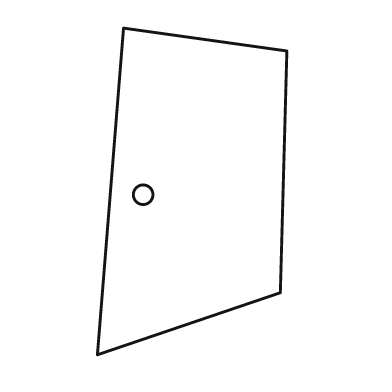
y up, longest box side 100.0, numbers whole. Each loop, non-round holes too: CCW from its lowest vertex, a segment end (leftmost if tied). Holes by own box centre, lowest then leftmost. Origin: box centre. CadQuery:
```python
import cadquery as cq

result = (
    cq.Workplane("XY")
    .moveTo(-29.0, -50.0)
    .lineTo(27.0, -31.0)
    .lineTo(29.0, 43.0)
    .lineTo(-21.0, 50.0)
    .close()
    .moveTo(-15.0, -1.0)
    .circle(3.0)
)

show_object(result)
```